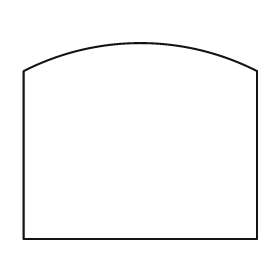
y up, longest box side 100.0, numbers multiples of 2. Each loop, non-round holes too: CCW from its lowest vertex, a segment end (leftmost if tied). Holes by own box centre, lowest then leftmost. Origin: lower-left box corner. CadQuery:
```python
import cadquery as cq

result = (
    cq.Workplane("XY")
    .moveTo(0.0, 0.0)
    .lineTo(100.0, 0.0)
    .lineTo(100.0, 72.0)
    .threePointArc((50.0, 84.0), (0.0, 72.0))
    .close()
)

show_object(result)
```